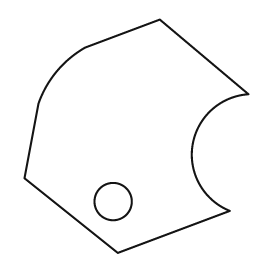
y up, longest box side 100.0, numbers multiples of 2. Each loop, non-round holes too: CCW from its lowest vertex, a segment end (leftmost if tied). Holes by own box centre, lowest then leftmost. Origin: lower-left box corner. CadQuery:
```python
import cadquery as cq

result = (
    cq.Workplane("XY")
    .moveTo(40.0, 0.0)
    .lineTo(88.0, 18.0)
    .threePointArc((72.0, 46.0), (96.0, 68.0))
    .lineTo(58.0, 100.0)
    .lineTo(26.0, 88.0)
    .threePointArc((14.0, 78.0), (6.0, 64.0))
    .lineTo(0.0, 32.0)
    .close()
    .moveTo(38.0, 22.0)
    .circle(8.0)
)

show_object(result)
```